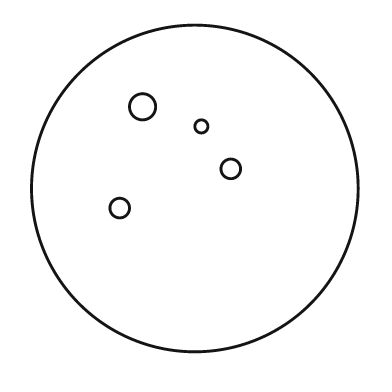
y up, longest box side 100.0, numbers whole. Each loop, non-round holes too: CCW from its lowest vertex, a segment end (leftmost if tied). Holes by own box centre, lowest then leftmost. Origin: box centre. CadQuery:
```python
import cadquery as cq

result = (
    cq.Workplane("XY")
    .moveTo(0.0, 0.0)
    .circle(50.0)
    .moveTo(-23.0, -6.0)
    .circle(3.0)
    .moveTo(11.0, 6.0)
    .circle(3.0)
    .moveTo(2.0, 19.0)
    .circle(2.0)
    .moveTo(-16.0, 25.0)
    .circle(4.0)
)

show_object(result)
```